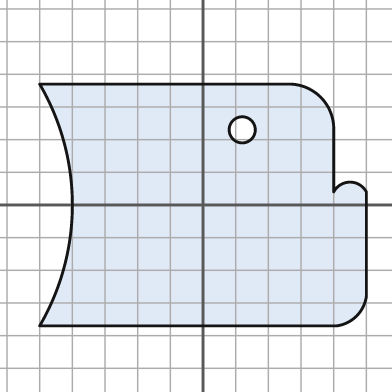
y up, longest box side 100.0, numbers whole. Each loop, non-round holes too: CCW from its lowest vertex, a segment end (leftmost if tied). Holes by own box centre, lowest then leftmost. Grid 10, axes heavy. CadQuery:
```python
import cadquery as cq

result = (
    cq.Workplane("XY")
    .moveTo(-50.0, -37.0)
    .lineTo(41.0, -37.0)
    .threePointArc((47.0, -34.0), (50.0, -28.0))
    .lineTo(50.0, 4.0)
    .threePointArc((45.0, 7.0), (40.0, 4.0))
    .lineTo(40.0, 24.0)
    .threePointArc((36.0, 33.0), (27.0, 37.0))
    .lineTo(-50.0, 37.0)
    .threePointArc((-40.0, 0.0), (-50.0, -37.0))
    .close()
    .moveTo(12.0, 23.0)
    .circle(4.0)
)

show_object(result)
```